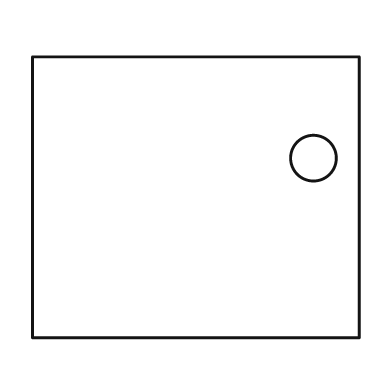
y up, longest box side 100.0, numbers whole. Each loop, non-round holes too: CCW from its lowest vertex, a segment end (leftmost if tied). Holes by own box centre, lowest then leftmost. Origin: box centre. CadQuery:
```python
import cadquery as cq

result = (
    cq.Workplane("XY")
    .moveTo(-50.0, -43.0)
    .lineTo(50.0, -43.0)
    .lineTo(50.0, 43.0)
    .lineTo(-50.0, 43.0)
    .close()
    .moveTo(36.0, 12.0)
    .circle(7.0)
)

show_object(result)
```